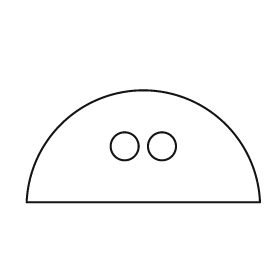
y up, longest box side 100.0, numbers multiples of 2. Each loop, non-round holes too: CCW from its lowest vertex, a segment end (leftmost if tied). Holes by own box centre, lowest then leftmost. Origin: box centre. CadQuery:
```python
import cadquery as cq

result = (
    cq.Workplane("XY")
    .moveTo(-50.0, -24.0)
    .lineTo(50.0, -24.0)
    .threePointArc((0.0, 24.0), (-50.0, -24.0))
    .close()
    .moveTo(-8.0, 0.0)
    .circle(6.0)
    .moveTo(8.0, 0.0)
    .circle(6.0)
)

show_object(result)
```